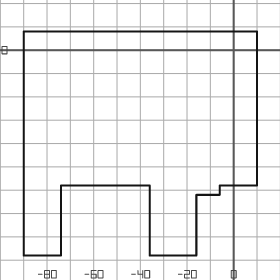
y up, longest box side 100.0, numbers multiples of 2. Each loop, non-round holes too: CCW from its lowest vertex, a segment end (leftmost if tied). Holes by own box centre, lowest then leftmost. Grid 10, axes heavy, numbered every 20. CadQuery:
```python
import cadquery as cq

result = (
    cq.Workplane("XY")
    .moveTo(-90.0, -88.0)
    .lineTo(-74.0, -88.0)
    .lineTo(-74.0, -58.0)
    .lineTo(-36.0, -58.0)
    .lineTo(-36.0, -88.0)
    .lineTo(-16.0, -88.0)
    .lineTo(-16.0, -62.0)
    .lineTo(-6.0, -62.0)
    .lineTo(-6.0, -58.0)
    .lineTo(10.0, -58.0)
    .lineTo(10.0, 8.0)
    .lineTo(-90.0, 8.0)
    .close()
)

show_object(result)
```